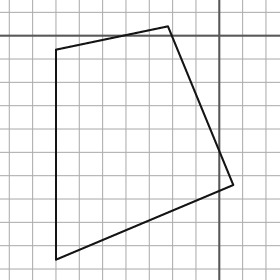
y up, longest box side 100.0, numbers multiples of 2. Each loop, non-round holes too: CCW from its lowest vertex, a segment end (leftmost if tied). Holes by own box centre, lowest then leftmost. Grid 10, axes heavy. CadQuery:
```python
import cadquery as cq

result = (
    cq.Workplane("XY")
    .moveTo(-70.0, -96.0)
    .lineTo(6.0, -64.0)
    .lineTo(-22.0, 4.0)
    .lineTo(-70.0, -6.0)
    .close()
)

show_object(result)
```